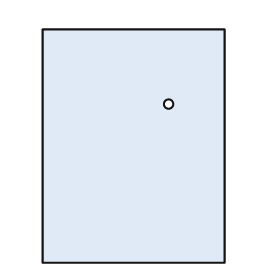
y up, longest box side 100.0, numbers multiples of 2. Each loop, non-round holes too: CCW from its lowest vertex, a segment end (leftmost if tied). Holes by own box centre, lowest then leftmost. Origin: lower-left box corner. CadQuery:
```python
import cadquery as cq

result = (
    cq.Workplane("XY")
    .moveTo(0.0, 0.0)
    .lineTo(78.0, 0.0)
    .lineTo(78.0, 100.0)
    .lineTo(0.0, 100.0)
    .close()
    .moveTo(54.0, 68.0)
    .circle(2.0)
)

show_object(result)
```